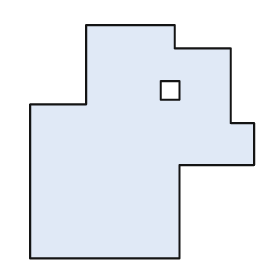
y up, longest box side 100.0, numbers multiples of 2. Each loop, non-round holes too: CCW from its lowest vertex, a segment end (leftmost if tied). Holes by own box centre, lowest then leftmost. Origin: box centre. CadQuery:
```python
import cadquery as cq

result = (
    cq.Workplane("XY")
    .moveTo(-48.0, -50.0)
    .lineTo(16.0, -50.0)
    .lineTo(16.0, -10.0)
    .lineTo(48.0, -10.0)
    .lineTo(48.0, 8.0)
    .lineTo(38.0, 8.0)
    .lineTo(38.0, 40.0)
    .lineTo(14.0, 40.0)
    .lineTo(14.0, 50.0)
    .lineTo(-24.0, 50.0)
    .lineTo(-24.0, 16.0)
    .lineTo(-48.0, 16.0)
    .close()
    .moveTo(8.0, 18.0)
    .lineTo(16.0, 18.0)
    .lineTo(16.0, 26.0)
    .lineTo(8.0, 26.0)
    .close()
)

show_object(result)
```